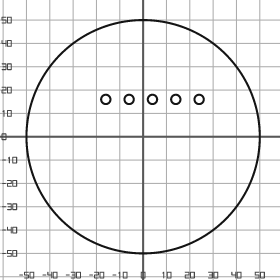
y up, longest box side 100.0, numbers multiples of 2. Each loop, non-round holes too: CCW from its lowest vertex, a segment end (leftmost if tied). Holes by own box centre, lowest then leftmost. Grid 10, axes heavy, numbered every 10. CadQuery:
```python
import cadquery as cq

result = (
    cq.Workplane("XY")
    .moveTo(0.0, 0.0)
    .circle(50.0)
    .moveTo(-16.0, 16.0)
    .circle(2.0)
    .moveTo(-6.0, 16.0)
    .circle(2.0)
    .moveTo(4.0, 16.0)
    .circle(2.0)
    .moveTo(14.0, 16.0)
    .circle(2.0)
    .moveTo(24.0, 16.0)
    .circle(2.0)
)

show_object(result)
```